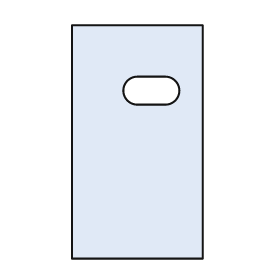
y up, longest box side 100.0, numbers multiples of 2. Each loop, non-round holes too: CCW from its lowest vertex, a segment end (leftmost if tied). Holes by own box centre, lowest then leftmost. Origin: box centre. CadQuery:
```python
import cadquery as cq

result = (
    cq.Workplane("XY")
    .moveTo(-28.0, -50.0)
    .lineTo(28.0, -50.0)
    .lineTo(28.0, 50.0)
    .lineTo(-28.0, 50.0)
    .close()
    .moveTo(0.0, 16.0)
    .lineTo(12.0, 16.0)
    .threePointArc((18.0, 22.0), (12.0, 28.0))
    .lineTo(0.0, 28.0)
    .threePointArc((-6.0, 22.0), (0.0, 16.0))
    .close()
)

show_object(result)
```